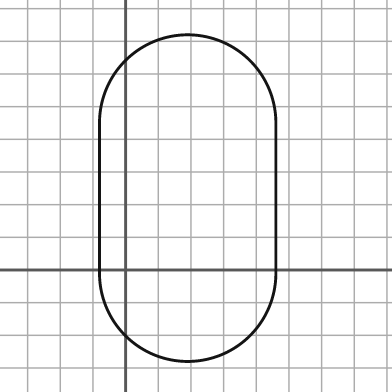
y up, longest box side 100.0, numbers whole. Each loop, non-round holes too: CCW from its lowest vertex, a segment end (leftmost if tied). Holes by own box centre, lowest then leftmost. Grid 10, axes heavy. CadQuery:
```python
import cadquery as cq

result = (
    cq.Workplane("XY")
    .moveTo(-8.0, -1.0)
    .threePointArc((19.0, -28.0), (46.0, -1.0))
    .lineTo(46.0, 45.0)
    .threePointArc((19.0, 72.0), (-8.0, 45.0))
    .close()
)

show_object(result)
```